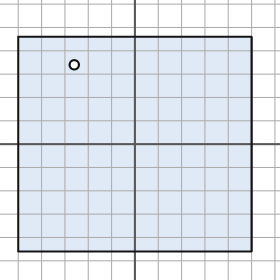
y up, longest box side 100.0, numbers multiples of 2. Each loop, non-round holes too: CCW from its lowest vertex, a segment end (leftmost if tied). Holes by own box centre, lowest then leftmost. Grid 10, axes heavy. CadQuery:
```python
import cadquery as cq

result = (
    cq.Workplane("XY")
    .moveTo(-50.0, -46.0)
    .lineTo(50.0, -46.0)
    .lineTo(50.0, 46.0)
    .lineTo(-50.0, 46.0)
    .close()
    .moveTo(-26.0, 34.0)
    .circle(2.0)
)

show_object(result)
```